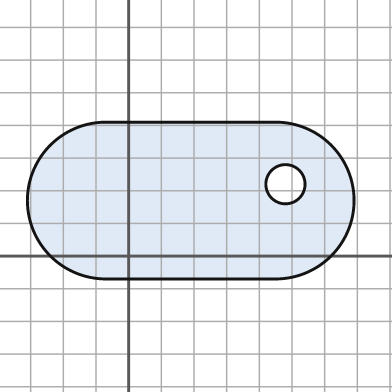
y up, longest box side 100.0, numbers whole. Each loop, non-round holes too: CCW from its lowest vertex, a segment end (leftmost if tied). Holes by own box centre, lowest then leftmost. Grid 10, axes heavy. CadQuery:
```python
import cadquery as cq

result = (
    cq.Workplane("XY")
    .moveTo(-7.0, -7.0)
    .lineTo(45.0, -7.0)
    .threePointArc((69.0, 17.0), (45.0, 41.0))
    .lineTo(-7.0, 41.0)
    .threePointArc((-31.0, 17.0), (-7.0, -7.0))
    .close()
    .moveTo(48.0, 22.0)
    .circle(6.0)
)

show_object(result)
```